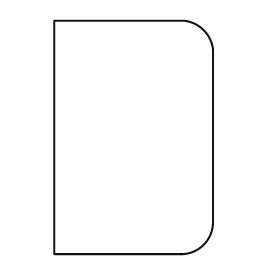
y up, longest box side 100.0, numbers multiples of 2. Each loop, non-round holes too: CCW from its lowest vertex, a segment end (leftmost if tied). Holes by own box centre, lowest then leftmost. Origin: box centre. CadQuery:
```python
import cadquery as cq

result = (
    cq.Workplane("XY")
    .moveTo(-34.0, -50.0)
    .lineTo(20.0, -50.0)
    .threePointArc((30.0, -46.0), (34.0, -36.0))
    .lineTo(34.0, 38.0)
    .threePointArc((30.0, 46.0), (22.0, 50.0))
    .lineTo(-34.0, 50.0)
    .close()
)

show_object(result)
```